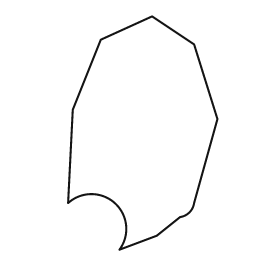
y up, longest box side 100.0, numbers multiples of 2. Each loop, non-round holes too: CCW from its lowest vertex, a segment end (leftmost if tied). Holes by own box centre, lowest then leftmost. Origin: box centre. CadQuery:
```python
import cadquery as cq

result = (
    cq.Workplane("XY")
    .moveTo(-10.0, -50.0)
    .lineTo(6.0, -44.0)
    .lineTo(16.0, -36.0)
    .threePointArc((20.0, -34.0), (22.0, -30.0))
    .lineTo(32.0, 6.0)
    .lineTo(22.0, 38.0)
    .lineTo(4.0, 50.0)
    .lineTo(-18.0, 40.0)
    .lineTo(-30.0, 10.0)
    .lineTo(-32.0, -30.0)
    .threePointArc((-12.0, -30.0), (-10.0, -50.0))
    .close()
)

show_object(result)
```